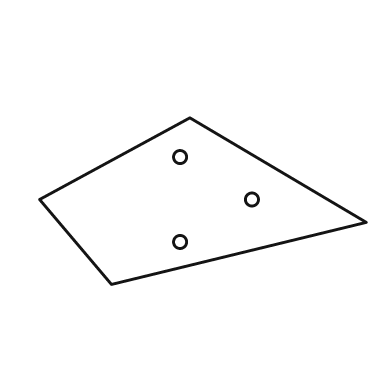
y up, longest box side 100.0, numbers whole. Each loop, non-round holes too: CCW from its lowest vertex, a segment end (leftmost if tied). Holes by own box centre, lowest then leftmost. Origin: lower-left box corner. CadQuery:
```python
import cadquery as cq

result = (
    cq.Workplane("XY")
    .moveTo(22.0, 0.0)
    .lineTo(100.0, 19.0)
    .lineTo(46.0, 51.0)
    .lineTo(0.0, 26.0)
    .close()
    .moveTo(43.0, 13.0)
    .circle(2.0)
    .moveTo(65.0, 26.0)
    .circle(2.0)
    .moveTo(43.0, 39.0)
    .circle(2.0)
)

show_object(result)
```